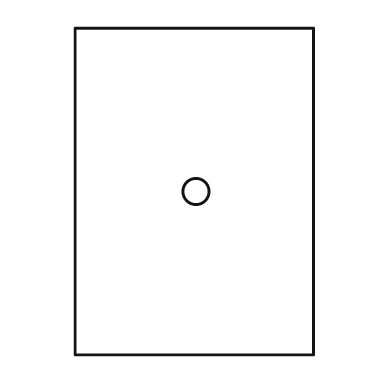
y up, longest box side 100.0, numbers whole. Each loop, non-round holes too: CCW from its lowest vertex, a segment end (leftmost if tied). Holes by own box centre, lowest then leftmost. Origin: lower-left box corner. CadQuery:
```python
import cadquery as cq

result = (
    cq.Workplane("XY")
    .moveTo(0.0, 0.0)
    .lineTo(73.0, 0.0)
    .lineTo(73.0, 100.0)
    .lineTo(0.0, 100.0)
    .close()
    .moveTo(37.0, 50.0)
    .circle(4.0)
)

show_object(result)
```